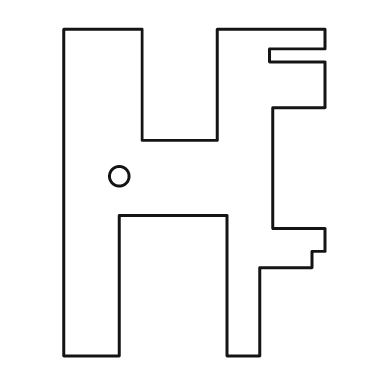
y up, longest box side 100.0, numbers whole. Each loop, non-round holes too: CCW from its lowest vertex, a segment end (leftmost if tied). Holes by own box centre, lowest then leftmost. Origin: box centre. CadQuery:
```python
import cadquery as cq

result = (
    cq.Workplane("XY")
    .moveTo(-40.0, -50.0)
    .lineTo(-23.0, -50.0)
    .lineTo(-23.0, -7.0)
    .lineTo(10.0, -7.0)
    .lineTo(10.0, -50.0)
    .lineTo(20.0, -50.0)
    .lineTo(20.0, -23.0)
    .lineTo(36.0, -23.0)
    .lineTo(36.0, -18.0)
    .lineTo(40.0, -18.0)
    .lineTo(40.0, -11.0)
    .lineTo(24.0, -11.0)
    .lineTo(24.0, 26.0)
    .lineTo(40.0, 26.0)
    .lineTo(40.0, 40.0)
    .lineTo(23.0, 40.0)
    .lineTo(23.0, 44.0)
    .lineTo(40.0, 44.0)
    .lineTo(40.0, 50.0)
    .lineTo(7.0, 50.0)
    .lineTo(7.0, 16.0)
    .lineTo(-16.0, 16.0)
    .lineTo(-16.0, 50.0)
    .lineTo(-40.0, 50.0)
    .close()
    .moveTo(-23.0, 5.0)
    .circle(3.0)
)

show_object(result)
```